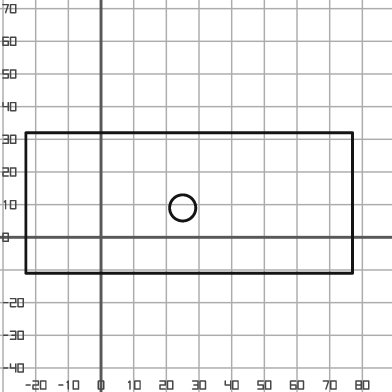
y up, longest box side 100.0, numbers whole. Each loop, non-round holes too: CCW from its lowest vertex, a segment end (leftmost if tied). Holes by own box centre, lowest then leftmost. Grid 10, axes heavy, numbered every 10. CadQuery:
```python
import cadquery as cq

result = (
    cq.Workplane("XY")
    .moveTo(-23.0, -11.0)
    .lineTo(77.0, -11.0)
    .lineTo(77.0, 32.0)
    .lineTo(-23.0, 32.0)
    .close()
    .moveTo(25.0, 9.0)
    .circle(4.0)
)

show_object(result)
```